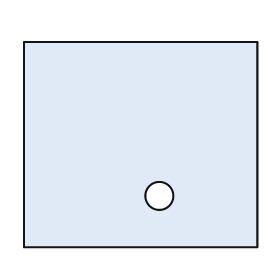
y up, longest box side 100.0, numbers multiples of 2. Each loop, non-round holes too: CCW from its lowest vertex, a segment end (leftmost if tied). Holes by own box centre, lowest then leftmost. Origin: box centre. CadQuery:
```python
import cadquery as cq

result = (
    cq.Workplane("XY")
    .moveTo(-50.0, -44.0)
    .lineTo(50.0, -44.0)
    .lineTo(50.0, 44.0)
    .lineTo(-50.0, 44.0)
    .close()
    .moveTo(8.0, -22.0)
    .circle(6.0)
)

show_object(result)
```